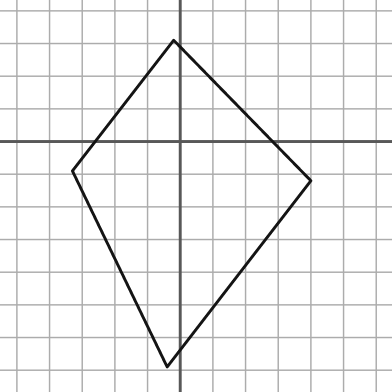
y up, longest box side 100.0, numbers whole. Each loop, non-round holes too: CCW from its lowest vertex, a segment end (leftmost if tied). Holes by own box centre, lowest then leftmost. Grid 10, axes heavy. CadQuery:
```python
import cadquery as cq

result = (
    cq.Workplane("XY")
    .moveTo(-4.0, -69.0)
    .lineTo(40.0, -12.0)
    .lineTo(-2.0, 31.0)
    .lineTo(-33.0, -9.0)
    .close()
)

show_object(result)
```